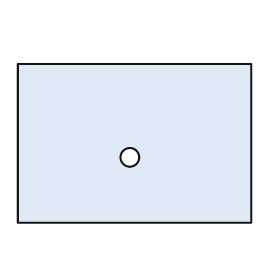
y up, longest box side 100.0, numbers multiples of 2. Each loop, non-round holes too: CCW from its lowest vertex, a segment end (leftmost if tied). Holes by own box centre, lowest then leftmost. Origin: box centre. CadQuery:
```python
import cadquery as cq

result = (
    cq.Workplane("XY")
    .moveTo(-50.0, -34.0)
    .lineTo(50.0, -34.0)
    .lineTo(50.0, 34.0)
    .lineTo(-50.0, 34.0)
    .close()
    .moveTo(-2.0, -6.0)
    .circle(4.0)
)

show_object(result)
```